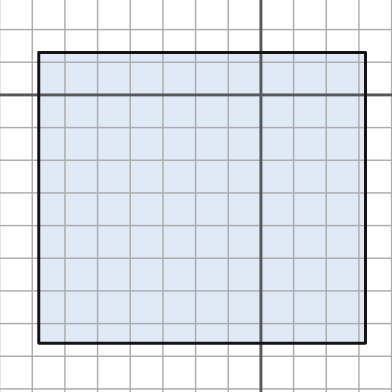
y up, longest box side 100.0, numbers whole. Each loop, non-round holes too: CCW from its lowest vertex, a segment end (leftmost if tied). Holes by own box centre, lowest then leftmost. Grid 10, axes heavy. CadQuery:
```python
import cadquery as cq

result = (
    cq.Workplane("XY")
    .moveTo(-68.0, -76.0)
    .lineTo(32.0, -76.0)
    .lineTo(32.0, 13.0)
    .lineTo(-68.0, 13.0)
    .close()
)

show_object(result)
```